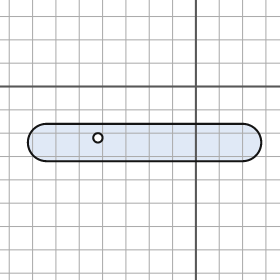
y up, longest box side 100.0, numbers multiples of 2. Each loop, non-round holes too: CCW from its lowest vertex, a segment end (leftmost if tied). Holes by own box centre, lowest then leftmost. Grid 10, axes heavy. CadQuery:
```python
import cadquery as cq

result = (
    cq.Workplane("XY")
    .moveTo(-64.0, -32.0)
    .lineTo(20.0, -32.0)
    .threePointArc((28.0, -24.0), (20.0, -16.0))
    .lineTo(-64.0, -16.0)
    .threePointArc((-72.0, -24.0), (-64.0, -32.0))
    .close()
    .moveTo(-42.0, -22.0)
    .circle(2.0)
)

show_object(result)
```